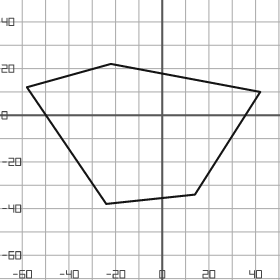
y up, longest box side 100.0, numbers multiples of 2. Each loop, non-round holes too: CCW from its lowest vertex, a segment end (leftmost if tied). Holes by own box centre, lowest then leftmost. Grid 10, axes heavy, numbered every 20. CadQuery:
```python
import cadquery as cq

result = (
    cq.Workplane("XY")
    .moveTo(-24.0, -38.0)
    .lineTo(14.0, -34.0)
    .lineTo(42.0, 10.0)
    .lineTo(-22.0, 22.0)
    .lineTo(-58.0, 12.0)
    .close()
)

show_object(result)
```